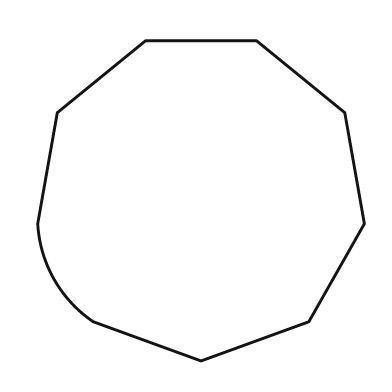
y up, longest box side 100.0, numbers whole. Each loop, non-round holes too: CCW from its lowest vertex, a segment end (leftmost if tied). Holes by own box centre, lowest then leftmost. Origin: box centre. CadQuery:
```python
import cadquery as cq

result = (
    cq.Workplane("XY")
    .moveTo(0.0, -49.0)
    .lineTo(33.0, -37.0)
    .lineTo(50.0, -7.0)
    .lineTo(44.0, 27.0)
    .lineTo(17.0, 49.0)
    .lineTo(-17.0, 49.0)
    .lineTo(-44.0, 27.0)
    .lineTo(-50.0, -7.0)
    .threePointArc((-45.0, -24.0), (-33.0, -37.0))
    .close()
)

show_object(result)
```